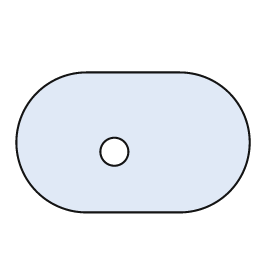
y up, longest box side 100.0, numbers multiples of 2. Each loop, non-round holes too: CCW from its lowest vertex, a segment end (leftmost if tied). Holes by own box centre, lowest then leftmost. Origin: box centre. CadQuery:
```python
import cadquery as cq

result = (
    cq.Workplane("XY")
    .moveTo(-20.0, -30.0)
    .lineTo(20.0, -30.0)
    .threePointArc((50.0, 0.0), (20.0, 30.0))
    .lineTo(-20.0, 30.0)
    .threePointArc((-50.0, 0.0), (-20.0, -30.0))
    .close()
    .moveTo(-8.0, -4.0)
    .circle(6.0)
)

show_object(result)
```